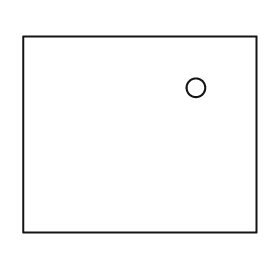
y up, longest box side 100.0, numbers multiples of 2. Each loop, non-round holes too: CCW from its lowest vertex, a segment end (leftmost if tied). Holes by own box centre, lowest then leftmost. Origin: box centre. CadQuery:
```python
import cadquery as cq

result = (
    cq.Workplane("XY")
    .moveTo(-50.0, -42.0)
    .lineTo(50.0, -42.0)
    .lineTo(50.0, 42.0)
    .lineTo(-50.0, 42.0)
    .close()
    .moveTo(24.0, 20.0)
    .circle(4.0)
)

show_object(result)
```